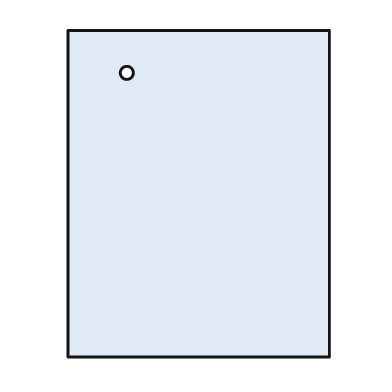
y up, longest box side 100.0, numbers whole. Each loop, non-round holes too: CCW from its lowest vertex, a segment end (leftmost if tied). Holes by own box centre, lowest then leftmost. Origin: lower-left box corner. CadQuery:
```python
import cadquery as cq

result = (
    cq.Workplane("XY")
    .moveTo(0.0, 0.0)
    .lineTo(80.0, 0.0)
    .lineTo(80.0, 100.0)
    .lineTo(0.0, 100.0)
    .close()
    .moveTo(18.0, 87.0)
    .circle(2.0)
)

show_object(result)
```